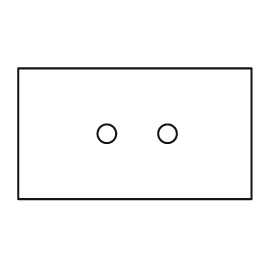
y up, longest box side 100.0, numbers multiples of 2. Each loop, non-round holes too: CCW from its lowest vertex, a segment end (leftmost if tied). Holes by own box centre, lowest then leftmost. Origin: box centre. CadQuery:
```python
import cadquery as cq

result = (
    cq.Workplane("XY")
    .moveTo(-50.0, -28.0)
    .lineTo(50.0, -28.0)
    .lineTo(50.0, 28.0)
    .lineTo(-50.0, 28.0)
    .close()
    .moveTo(-12.0, 0.0)
    .circle(4.0)
    .moveTo(14.0, 0.0)
    .circle(4.0)
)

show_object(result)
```